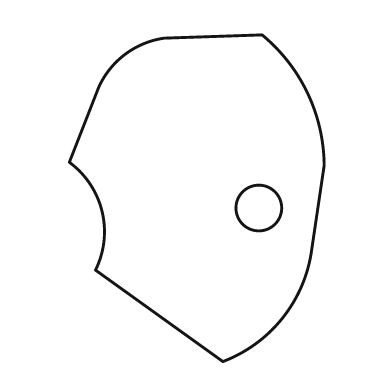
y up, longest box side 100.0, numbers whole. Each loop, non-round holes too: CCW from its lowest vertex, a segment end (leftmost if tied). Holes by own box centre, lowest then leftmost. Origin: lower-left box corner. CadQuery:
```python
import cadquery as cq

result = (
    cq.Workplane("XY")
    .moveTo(47.0, 0.0)
    .threePointArc((65.0, 13.0), (74.0, 33.0))
    .lineTo(78.0, 60.0)
    .threePointArc((73.0, 82.0), (59.0, 100.0))
    .lineTo(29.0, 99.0)
    .threePointArc((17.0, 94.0), (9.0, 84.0))
    .lineTo(0.0, 61.0)
    .threePointArc((10.0, 46.0), (8.0, 28.0))
    .close()
    .moveTo(58.0, 47.0)
    .circle(7.0)
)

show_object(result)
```